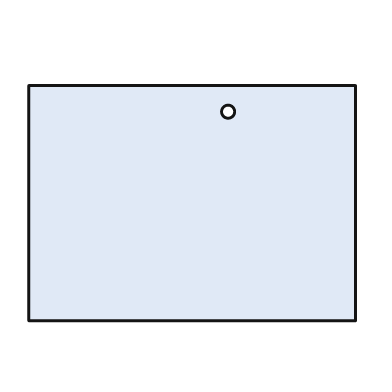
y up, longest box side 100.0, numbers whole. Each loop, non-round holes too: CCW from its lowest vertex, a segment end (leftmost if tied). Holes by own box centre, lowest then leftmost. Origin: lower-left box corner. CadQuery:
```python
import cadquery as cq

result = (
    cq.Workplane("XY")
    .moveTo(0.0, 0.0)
    .lineTo(100.0, 0.0)
    .lineTo(100.0, 72.0)
    .lineTo(0.0, 72.0)
    .close()
    .moveTo(61.0, 64.0)
    .circle(2.0)
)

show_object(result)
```